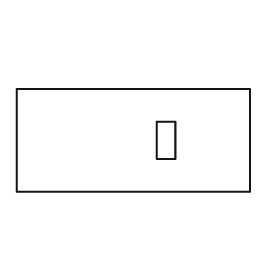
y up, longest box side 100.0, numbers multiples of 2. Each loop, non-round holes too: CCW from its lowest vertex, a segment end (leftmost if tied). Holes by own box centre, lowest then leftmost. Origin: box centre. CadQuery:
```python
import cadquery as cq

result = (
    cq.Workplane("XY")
    .moveTo(-50.0, -22.0)
    .lineTo(50.0, -22.0)
    .lineTo(50.0, 22.0)
    .lineTo(-50.0, 22.0)
    .close()
    .moveTo(10.0, -8.0)
    .lineTo(18.0, -8.0)
    .lineTo(18.0, 8.0)
    .lineTo(10.0, 8.0)
    .close()
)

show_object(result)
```